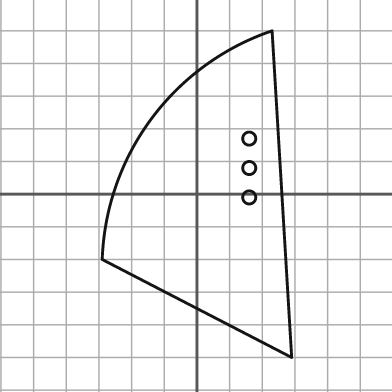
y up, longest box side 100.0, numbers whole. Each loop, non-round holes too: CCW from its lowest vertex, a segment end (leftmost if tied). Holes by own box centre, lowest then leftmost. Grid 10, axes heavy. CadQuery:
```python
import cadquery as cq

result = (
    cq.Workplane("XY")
    .moveTo(29.0, -50.0)
    .lineTo(23.0, 50.0)
    .threePointArc((-14.0, 23.0), (-29.0, -20.0))
    .close()
    .moveTo(16.0, -1.0)
    .circle(2.0)
    .moveTo(16.0, 8.0)
    .circle(2.0)
    .moveTo(16.0, 17.0)
    .circle(2.0)
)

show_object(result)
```